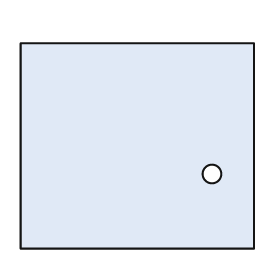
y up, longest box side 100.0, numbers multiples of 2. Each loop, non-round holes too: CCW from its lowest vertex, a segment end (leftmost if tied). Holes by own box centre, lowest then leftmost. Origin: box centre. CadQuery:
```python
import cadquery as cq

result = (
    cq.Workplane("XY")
    .moveTo(-50.0, -44.0)
    .lineTo(50.0, -44.0)
    .lineTo(50.0, 44.0)
    .lineTo(-50.0, 44.0)
    .close()
    .moveTo(32.0, -12.0)
    .circle(4.0)
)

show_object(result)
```